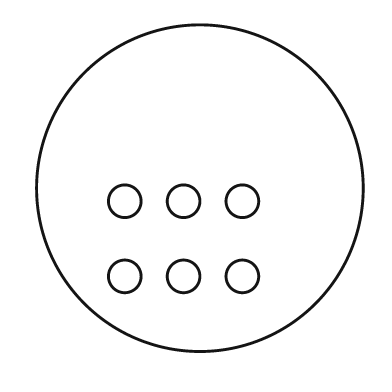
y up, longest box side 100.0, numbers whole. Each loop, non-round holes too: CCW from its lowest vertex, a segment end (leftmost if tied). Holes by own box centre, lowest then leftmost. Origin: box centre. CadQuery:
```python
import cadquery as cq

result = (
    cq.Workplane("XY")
    .moveTo(0.0, 0.0)
    .circle(50.0)
    .moveTo(-23.0, -27.0)
    .circle(5.0)
    .moveTo(-5.0, -27.0)
    .circle(5.0)
    .moveTo(13.0, -27.0)
    .circle(5.0)
    .moveTo(-23.0, -4.0)
    .circle(5.0)
    .moveTo(-5.0, -4.0)
    .circle(5.0)
    .moveTo(13.0, -4.0)
    .circle(5.0)
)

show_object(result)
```